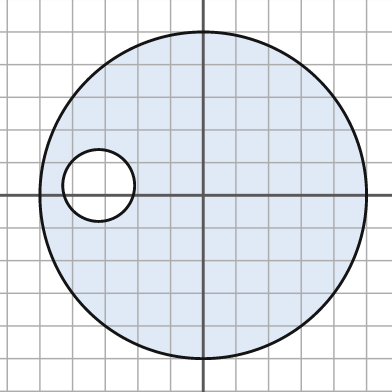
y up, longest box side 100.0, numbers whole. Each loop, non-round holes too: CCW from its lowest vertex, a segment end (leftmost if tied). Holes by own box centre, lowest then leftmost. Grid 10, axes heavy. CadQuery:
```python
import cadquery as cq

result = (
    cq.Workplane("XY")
    .moveTo(0.0, 0.0)
    .circle(50.0)
    .moveTo(-32.0, 3.0)
    .circle(11.0)
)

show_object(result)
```